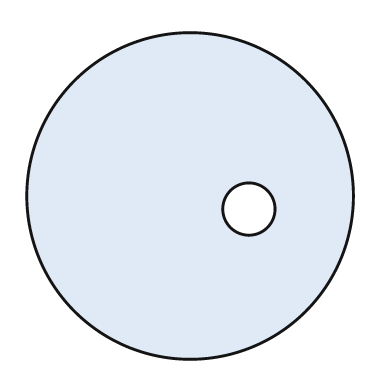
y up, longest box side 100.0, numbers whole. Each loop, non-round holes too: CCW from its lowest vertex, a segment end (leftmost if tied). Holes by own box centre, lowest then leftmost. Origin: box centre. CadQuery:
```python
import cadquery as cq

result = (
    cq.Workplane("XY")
    .moveTo(0.0, 0.0)
    .circle(50.0)
    .moveTo(18.0, -4.0)
    .circle(8.0)
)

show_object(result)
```